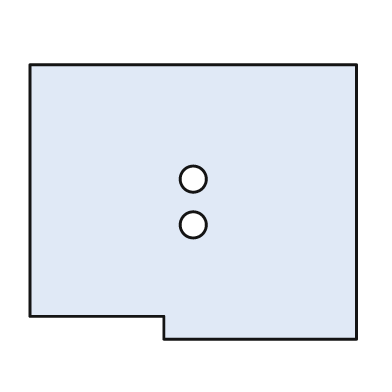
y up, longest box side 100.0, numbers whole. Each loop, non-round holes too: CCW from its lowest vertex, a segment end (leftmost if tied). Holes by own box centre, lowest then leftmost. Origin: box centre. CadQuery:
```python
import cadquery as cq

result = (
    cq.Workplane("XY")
    .moveTo(-9.0, -42.0)
    .lineTo(50.0, -42.0)
    .lineTo(50.0, 42.0)
    .lineTo(-50.0, 42.0)
    .lineTo(-50.0, -35.0)
    .lineTo(-9.0, -35.0)
    .close()
    .moveTo(0.0, -7.0)
    .circle(4.0)
    .moveTo(0.0, 7.0)
    .circle(4.0)
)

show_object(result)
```